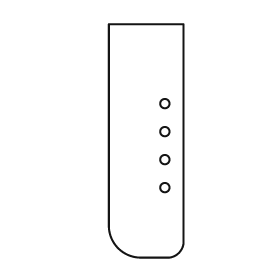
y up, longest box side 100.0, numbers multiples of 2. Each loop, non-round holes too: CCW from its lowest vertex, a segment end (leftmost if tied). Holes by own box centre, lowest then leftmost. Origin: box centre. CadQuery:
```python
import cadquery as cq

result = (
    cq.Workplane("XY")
    .moveTo(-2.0, -50.0)
    .lineTo(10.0, -50.0)
    .threePointArc((14.0, -48.0), (16.0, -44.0))
    .lineTo(16.0, 50.0)
    .lineTo(-16.0, 50.0)
    .lineTo(-16.0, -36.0)
    .threePointArc((-12.0, -46.0), (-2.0, -50.0))
    .close()
    .moveTo(8.0, -20.0)
    .circle(2.0)
    .moveTo(8.0, -8.0)
    .circle(2.0)
    .moveTo(8.0, 4.0)
    .circle(2.0)
    .moveTo(8.0, 16.0)
    .circle(2.0)
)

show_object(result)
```